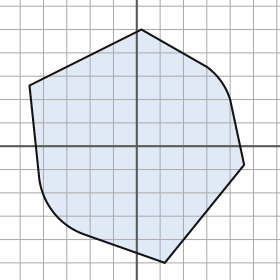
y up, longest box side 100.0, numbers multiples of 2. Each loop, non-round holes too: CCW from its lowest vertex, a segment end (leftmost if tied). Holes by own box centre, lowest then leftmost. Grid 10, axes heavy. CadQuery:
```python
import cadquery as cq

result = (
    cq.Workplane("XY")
    .moveTo(12.0, -50.0)
    .lineTo(46.0, -8.0)
    .lineTo(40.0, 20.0)
    .threePointArc((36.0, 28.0), (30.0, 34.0))
    .lineTo(2.0, 50.0)
    .lineTo(-46.0, 26.0)
    .lineTo(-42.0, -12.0)
    .threePointArc((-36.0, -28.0), (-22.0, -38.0))
    .close()
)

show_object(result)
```